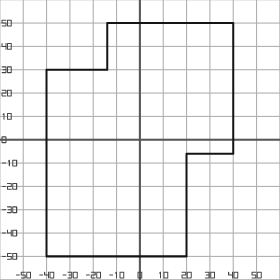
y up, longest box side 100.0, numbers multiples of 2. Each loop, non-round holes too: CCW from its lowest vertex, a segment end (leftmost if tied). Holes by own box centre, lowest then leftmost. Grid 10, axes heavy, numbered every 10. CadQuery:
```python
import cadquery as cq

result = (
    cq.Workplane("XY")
    .moveTo(-40.0, -50.0)
    .lineTo(20.0, -50.0)
    .lineTo(20.0, -6.0)
    .lineTo(40.0, -6.0)
    .lineTo(40.0, 50.0)
    .lineTo(-14.0, 50.0)
    .lineTo(-14.0, 30.0)
    .lineTo(-40.0, 30.0)
    .close()
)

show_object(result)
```